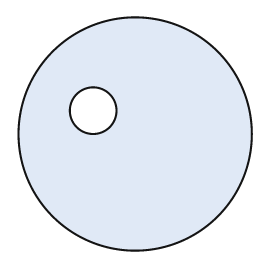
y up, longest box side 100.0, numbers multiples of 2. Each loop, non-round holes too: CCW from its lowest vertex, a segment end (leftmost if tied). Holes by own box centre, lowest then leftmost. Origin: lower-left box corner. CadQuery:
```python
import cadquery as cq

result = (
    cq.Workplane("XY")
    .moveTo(50.0, 50.0)
    .circle(50.0)
    .moveTo(32.0, 60.0)
    .circle(10.0)
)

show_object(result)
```